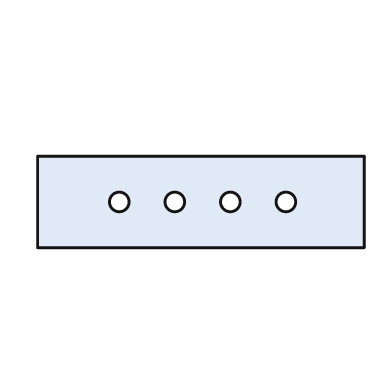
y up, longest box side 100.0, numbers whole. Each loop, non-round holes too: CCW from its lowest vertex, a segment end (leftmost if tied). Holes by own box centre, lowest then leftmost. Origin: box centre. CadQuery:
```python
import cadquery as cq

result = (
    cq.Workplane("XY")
    .moveTo(-50.0, -14.0)
    .lineTo(50.0, -14.0)
    .lineTo(50.0, 14.0)
    .lineTo(-50.0, 14.0)
    .close()
    .moveTo(-25.0, 0.0)
    .circle(3.0)
    .moveTo(-8.0, 0.0)
    .circle(3.0)
    .moveTo(9.0, 0.0)
    .circle(3.0)
    .moveTo(26.0, 0.0)
    .circle(3.0)
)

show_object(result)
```